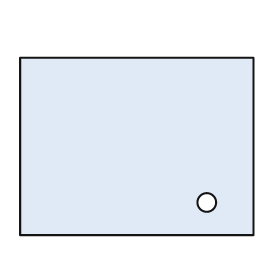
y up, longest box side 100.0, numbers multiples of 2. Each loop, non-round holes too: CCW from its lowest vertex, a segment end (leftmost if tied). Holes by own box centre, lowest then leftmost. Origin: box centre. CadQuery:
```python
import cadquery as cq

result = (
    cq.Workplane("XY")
    .moveTo(-50.0, -38.0)
    .lineTo(50.0, -38.0)
    .lineTo(50.0, 38.0)
    .lineTo(-50.0, 38.0)
    .close()
    .moveTo(30.0, -24.0)
    .circle(4.0)
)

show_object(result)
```